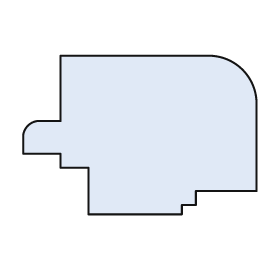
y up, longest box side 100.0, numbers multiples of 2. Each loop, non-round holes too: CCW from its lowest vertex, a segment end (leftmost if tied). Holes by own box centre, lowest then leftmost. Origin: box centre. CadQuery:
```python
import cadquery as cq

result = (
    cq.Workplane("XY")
    .moveTo(-22.0, -34.0)
    .lineTo(18.0, -34.0)
    .lineTo(18.0, -30.0)
    .lineTo(24.0, -30.0)
    .lineTo(24.0, -24.0)
    .lineTo(50.0, -24.0)
    .lineTo(50.0, 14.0)
    .threePointArc((44.0, 28.0), (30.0, 34.0))
    .lineTo(-34.0, 34.0)
    .lineTo(-34.0, 6.0)
    .lineTo(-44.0, 6.0)
    .threePointArc((-48.0, 4.0), (-50.0, 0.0))
    .lineTo(-50.0, -8.0)
    .lineTo(-34.0, -8.0)
    .lineTo(-34.0, -14.0)
    .lineTo(-22.0, -14.0)
    .close()
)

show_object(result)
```